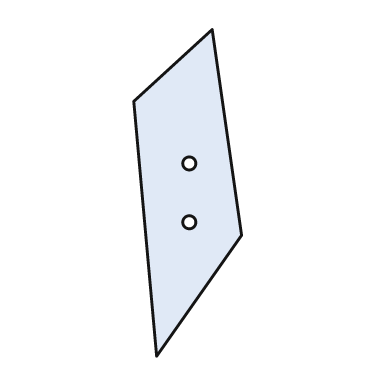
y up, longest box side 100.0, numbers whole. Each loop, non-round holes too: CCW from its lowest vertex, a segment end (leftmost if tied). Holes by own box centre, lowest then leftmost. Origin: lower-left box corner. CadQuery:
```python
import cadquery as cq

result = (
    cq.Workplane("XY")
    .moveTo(7.0, 0.0)
    .lineTo(33.0, 37.0)
    .lineTo(24.0, 100.0)
    .lineTo(0.0, 78.0)
    .close()
    .moveTo(17.0, 41.0)
    .circle(2.0)
    .moveTo(17.0, 59.0)
    .circle(2.0)
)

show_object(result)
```